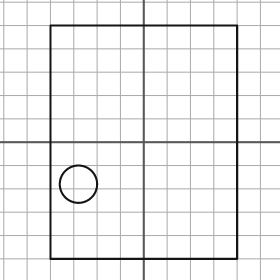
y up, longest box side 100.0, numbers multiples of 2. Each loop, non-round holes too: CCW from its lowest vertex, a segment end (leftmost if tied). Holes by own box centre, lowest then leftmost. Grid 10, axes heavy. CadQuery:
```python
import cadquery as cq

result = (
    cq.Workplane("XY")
    .moveTo(-40.0, -50.0)
    .lineTo(40.0, -50.0)
    .lineTo(40.0, 50.0)
    .lineTo(-40.0, 50.0)
    .close()
    .moveTo(-28.0, -18.0)
    .circle(8.0)
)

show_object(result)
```